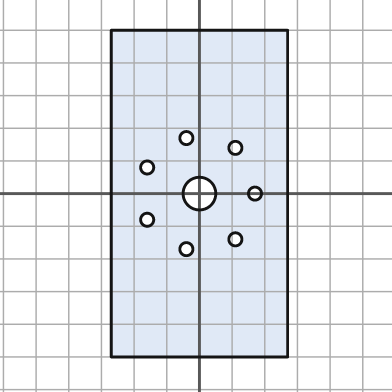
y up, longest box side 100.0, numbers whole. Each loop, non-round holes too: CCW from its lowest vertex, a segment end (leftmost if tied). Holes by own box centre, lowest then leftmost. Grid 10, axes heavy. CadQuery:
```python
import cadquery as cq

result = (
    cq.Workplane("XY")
    .moveTo(-27.0, -50.0)
    .lineTo(27.0, -50.0)
    .lineTo(27.0, 50.0)
    .lineTo(-27.0, 50.0)
    .close()
    .moveTo(-4.0, -17.0)
    .circle(2.0)
    .moveTo(11.0, -14.0)
    .circle(2.0)
    .moveTo(-16.0, -8.0)
    .circle(2.0)
    .moveTo(0.0, 0.0)
    .circle(5.0)
    .moveTo(17.0, 0.0)
    .circle(2.0)
    .moveTo(-16.0, 8.0)
    .circle(2.0)
    .moveTo(11.0, 14.0)
    .circle(2.0)
    .moveTo(-4.0, 17.0)
    .circle(2.0)
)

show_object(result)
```